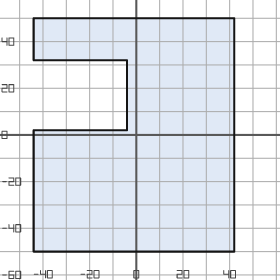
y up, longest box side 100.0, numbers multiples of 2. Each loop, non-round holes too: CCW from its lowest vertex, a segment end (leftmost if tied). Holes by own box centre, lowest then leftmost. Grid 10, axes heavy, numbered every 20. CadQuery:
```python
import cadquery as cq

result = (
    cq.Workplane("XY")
    .moveTo(-44.0, -50.0)
    .lineTo(42.0, -50.0)
    .lineTo(42.0, 50.0)
    .lineTo(-44.0, 50.0)
    .lineTo(-44.0, 32.0)
    .lineTo(-4.0, 32.0)
    .lineTo(-4.0, 2.0)
    .lineTo(-44.0, 2.0)
    .close()
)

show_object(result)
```